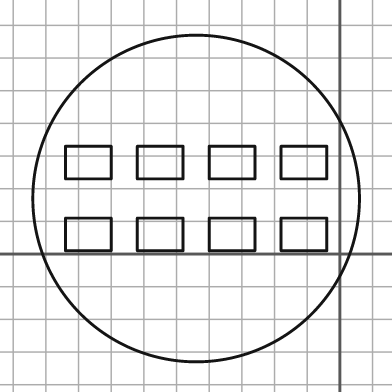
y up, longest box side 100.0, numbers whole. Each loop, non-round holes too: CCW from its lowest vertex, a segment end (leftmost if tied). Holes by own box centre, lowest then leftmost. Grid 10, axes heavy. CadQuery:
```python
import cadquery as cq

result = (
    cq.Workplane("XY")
    .moveTo(-44.0, 17.0)
    .circle(50.0)
    .moveTo(-84.0, 1.0)
    .lineTo(-70.0, 1.0)
    .lineTo(-70.0, 11.0)
    .lineTo(-84.0, 11.0)
    .close()
    .moveTo(-62.0, 1.0)
    .lineTo(-48.0, 1.0)
    .lineTo(-48.0, 11.0)
    .lineTo(-62.0, 11.0)
    .close()
    .moveTo(-40.0, 1.0)
    .lineTo(-26.0, 1.0)
    .lineTo(-26.0, 11.0)
    .lineTo(-40.0, 11.0)
    .close()
    .moveTo(-18.0, 1.0)
    .lineTo(-4.0, 1.0)
    .lineTo(-4.0, 11.0)
    .lineTo(-18.0, 11.0)
    .close()
    .moveTo(-84.0, 23.0)
    .lineTo(-70.0, 23.0)
    .lineTo(-70.0, 33.0)
    .lineTo(-84.0, 33.0)
    .close()
    .moveTo(-62.0, 23.0)
    .lineTo(-48.0, 23.0)
    .lineTo(-48.0, 33.0)
    .lineTo(-62.0, 33.0)
    .close()
    .moveTo(-40.0, 23.0)
    .lineTo(-26.0, 23.0)
    .lineTo(-26.0, 33.0)
    .lineTo(-40.0, 33.0)
    .close()
    .moveTo(-18.0, 23.0)
    .lineTo(-4.0, 23.0)
    .lineTo(-4.0, 33.0)
    .lineTo(-18.0, 33.0)
    .close()
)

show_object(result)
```